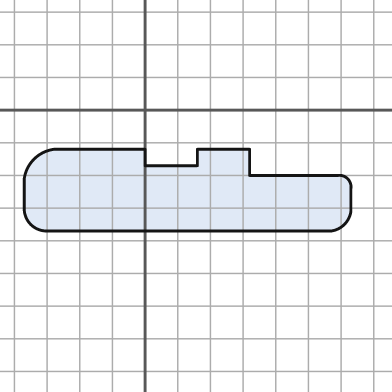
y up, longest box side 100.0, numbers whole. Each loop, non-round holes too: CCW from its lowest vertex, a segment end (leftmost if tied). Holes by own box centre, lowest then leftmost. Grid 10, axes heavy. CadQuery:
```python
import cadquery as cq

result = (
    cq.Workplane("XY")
    .moveTo(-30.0, -37.0)
    .lineTo(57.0, -37.0)
    .threePointArc((61.0, -35.0), (63.0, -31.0))
    .lineTo(63.0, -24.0)
    .threePointArc((62.0, -21.0), (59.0, -20.0))
    .lineTo(32.0, -20.0)
    .lineTo(32.0, -12.0)
    .lineTo(16.0, -12.0)
    .lineTo(16.0, -17.0)
    .lineTo(0.0, -17.0)
    .lineTo(0.0, -12.0)
    .lineTo(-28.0, -12.0)
    .threePointArc((-34.0, -15.0), (-37.0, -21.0))
    .lineTo(-37.0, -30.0)
    .threePointArc((-35.0, -35.0), (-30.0, -37.0))
    .close()
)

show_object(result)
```